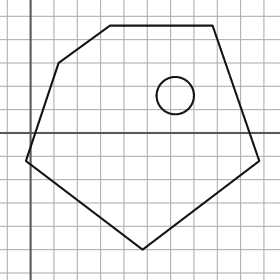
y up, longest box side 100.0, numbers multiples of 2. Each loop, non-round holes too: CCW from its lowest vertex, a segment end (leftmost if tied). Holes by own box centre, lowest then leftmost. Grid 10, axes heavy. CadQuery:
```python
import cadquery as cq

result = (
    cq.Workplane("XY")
    .moveTo(48.0, -50.0)
    .lineTo(98.0, -12.0)
    .lineTo(78.0, 46.0)
    .lineTo(34.0, 46.0)
    .lineTo(12.0, 30.0)
    .lineTo(-2.0, -12.0)
    .close()
    .moveTo(62.0, 16.0)
    .circle(8.0)
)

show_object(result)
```